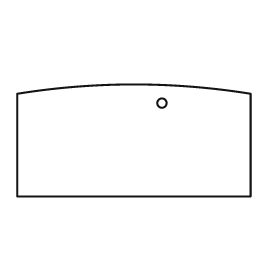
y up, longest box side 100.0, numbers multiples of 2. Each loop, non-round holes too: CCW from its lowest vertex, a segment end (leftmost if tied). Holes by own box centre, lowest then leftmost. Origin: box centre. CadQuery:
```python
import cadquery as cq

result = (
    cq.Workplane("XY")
    .moveTo(-50.0, -24.0)
    .lineTo(50.0, -24.0)
    .lineTo(50.0, 20.0)
    .threePointArc((0.0, 24.0), (-50.0, 20.0))
    .close()
    .moveTo(12.0, 16.0)
    .circle(2.0)
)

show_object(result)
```